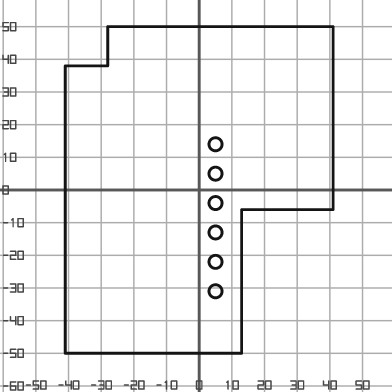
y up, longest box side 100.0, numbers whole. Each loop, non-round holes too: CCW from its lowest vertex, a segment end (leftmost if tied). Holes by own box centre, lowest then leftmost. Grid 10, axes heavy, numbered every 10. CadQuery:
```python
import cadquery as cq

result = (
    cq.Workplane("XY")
    .moveTo(-41.0, -50.0)
    .lineTo(13.0, -50.0)
    .lineTo(13.0, -6.0)
    .lineTo(41.0, -6.0)
    .lineTo(41.0, 50.0)
    .lineTo(-28.0, 50.0)
    .lineTo(-28.0, 38.0)
    .lineTo(-41.0, 38.0)
    .close()
    .moveTo(5.0, -31.0)
    .circle(2.0)
    .moveTo(5.0, -22.0)
    .circle(2.0)
    .moveTo(5.0, -13.0)
    .circle(2.0)
    .moveTo(5.0, -4.0)
    .circle(2.0)
    .moveTo(5.0, 5.0)
    .circle(2.0)
    .moveTo(5.0, 14.0)
    .circle(2.0)
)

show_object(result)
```